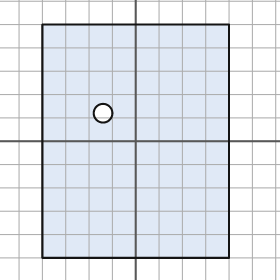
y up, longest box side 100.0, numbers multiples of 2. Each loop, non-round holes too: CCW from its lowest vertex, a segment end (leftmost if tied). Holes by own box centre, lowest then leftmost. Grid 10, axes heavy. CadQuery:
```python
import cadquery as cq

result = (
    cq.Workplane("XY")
    .moveTo(-40.0, -50.0)
    .lineTo(40.0, -50.0)
    .lineTo(40.0, 50.0)
    .lineTo(-40.0, 50.0)
    .close()
    .moveTo(-14.0, 12.0)
    .circle(4.0)
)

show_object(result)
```